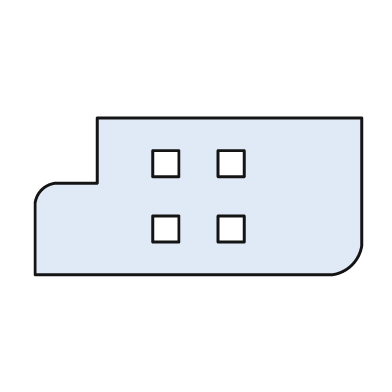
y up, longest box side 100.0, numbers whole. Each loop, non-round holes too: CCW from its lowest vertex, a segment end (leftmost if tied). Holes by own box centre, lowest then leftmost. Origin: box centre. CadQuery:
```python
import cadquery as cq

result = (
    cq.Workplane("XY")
    .moveTo(-50.0, -24.0)
    .lineTo(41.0, -24.0)
    .threePointArc((47.0, -21.0), (50.0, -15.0))
    .lineTo(50.0, 24.0)
    .lineTo(-31.0, 24.0)
    .lineTo(-31.0, 4.0)
    .lineTo(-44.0, 4.0)
    .threePointArc((-48.0, 2.0), (-50.0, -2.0))
    .close()
    .moveTo(-14.0, -14.0)
    .lineTo(-6.0, -14.0)
    .lineTo(-6.0, -6.0)
    .lineTo(-14.0, -6.0)
    .close()
    .moveTo(6.0, -14.0)
    .lineTo(14.0, -14.0)
    .lineTo(14.0, -6.0)
    .lineTo(6.0, -6.0)
    .close()
    .moveTo(-14.0, 6.0)
    .lineTo(-6.0, 6.0)
    .lineTo(-6.0, 14.0)
    .lineTo(-14.0, 14.0)
    .close()
    .moveTo(6.0, 6.0)
    .lineTo(14.0, 6.0)
    .lineTo(14.0, 14.0)
    .lineTo(6.0, 14.0)
    .close()
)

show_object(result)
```